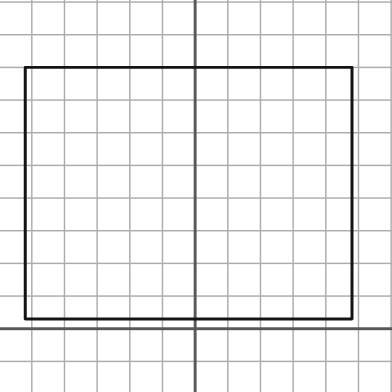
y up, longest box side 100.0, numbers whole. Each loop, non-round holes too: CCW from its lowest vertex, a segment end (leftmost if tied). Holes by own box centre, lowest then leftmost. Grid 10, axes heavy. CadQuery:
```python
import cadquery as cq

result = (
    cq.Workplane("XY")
    .moveTo(-52.0, 3.0)
    .lineTo(48.0, 3.0)
    .lineTo(48.0, 80.0)
    .lineTo(-52.0, 80.0)
    .close()
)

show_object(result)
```